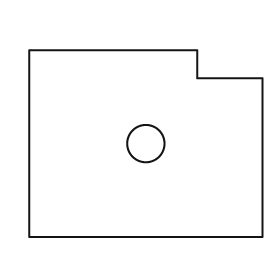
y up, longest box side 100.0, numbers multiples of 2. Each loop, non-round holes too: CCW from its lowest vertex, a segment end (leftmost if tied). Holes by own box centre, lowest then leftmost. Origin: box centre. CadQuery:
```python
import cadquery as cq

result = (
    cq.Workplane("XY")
    .moveTo(-50.0, -40.0)
    .lineTo(50.0, -40.0)
    .lineTo(50.0, 28.0)
    .lineTo(22.0, 28.0)
    .lineTo(22.0, 40.0)
    .lineTo(-50.0, 40.0)
    .close()
    .moveTo(0.0, 0.0)
    .circle(8.0)
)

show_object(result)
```